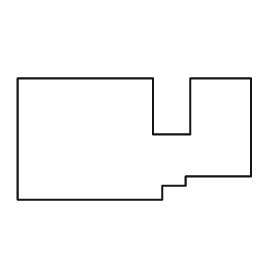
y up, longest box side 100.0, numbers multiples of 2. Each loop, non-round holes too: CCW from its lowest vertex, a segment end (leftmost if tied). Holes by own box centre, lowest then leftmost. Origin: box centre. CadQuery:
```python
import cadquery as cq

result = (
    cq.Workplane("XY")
    .moveTo(-50.0, -26.0)
    .lineTo(12.0, -26.0)
    .lineTo(12.0, -20.0)
    .lineTo(22.0, -20.0)
    .lineTo(22.0, -16.0)
    .lineTo(50.0, -16.0)
    .lineTo(50.0, 26.0)
    .lineTo(24.0, 26.0)
    .lineTo(24.0, 2.0)
    .lineTo(8.0, 2.0)
    .lineTo(8.0, 26.0)
    .lineTo(-50.0, 26.0)
    .close()
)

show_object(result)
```